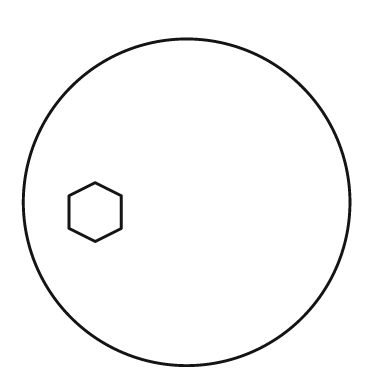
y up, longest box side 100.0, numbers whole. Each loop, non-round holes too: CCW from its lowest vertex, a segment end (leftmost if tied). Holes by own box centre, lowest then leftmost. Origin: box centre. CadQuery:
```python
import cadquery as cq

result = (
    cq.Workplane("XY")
    .moveTo(0.0, 0.0)
    .circle(50.0)
    .moveTo(-28.0, -12.0)
    .lineTo(-20.0, -8.0)
    .lineTo(-20.0, 2.0)
    .lineTo(-28.0, 6.0)
    .lineTo(-36.0, 2.0)
    .lineTo(-36.0, -8.0)
    .close()
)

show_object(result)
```